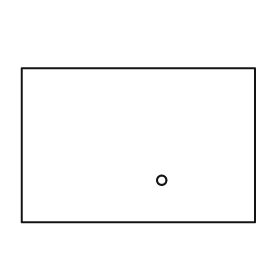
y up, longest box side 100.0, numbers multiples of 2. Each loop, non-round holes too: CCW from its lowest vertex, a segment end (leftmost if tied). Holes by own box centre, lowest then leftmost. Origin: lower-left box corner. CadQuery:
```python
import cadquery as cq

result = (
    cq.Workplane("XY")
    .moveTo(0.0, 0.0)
    .lineTo(100.0, 0.0)
    .lineTo(100.0, 66.0)
    .lineTo(0.0, 66.0)
    .close()
    .moveTo(60.0, 18.0)
    .circle(2.0)
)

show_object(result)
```